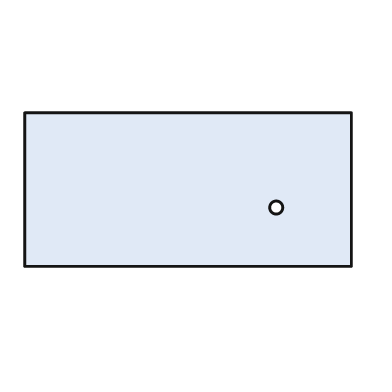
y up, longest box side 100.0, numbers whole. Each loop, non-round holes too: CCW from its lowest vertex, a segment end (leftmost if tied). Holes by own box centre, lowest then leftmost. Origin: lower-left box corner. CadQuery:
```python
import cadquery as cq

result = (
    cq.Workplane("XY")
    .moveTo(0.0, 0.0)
    .lineTo(100.0, 0.0)
    .lineTo(100.0, 47.0)
    .lineTo(0.0, 47.0)
    .close()
    .moveTo(77.0, 18.0)
    .circle(2.0)
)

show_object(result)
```